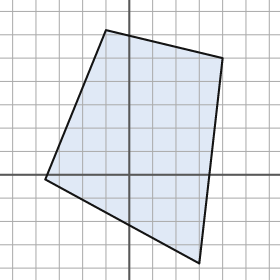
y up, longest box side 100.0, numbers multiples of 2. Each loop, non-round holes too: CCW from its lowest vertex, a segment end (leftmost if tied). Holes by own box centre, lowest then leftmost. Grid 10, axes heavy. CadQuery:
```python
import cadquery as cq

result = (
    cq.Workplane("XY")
    .moveTo(30.0, -38.0)
    .lineTo(40.0, 50.0)
    .lineTo(-10.0, 62.0)
    .lineTo(-36.0, -2.0)
    .close()
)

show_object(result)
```